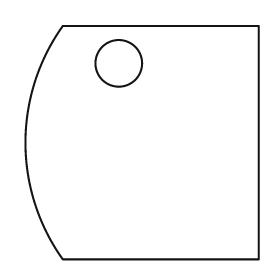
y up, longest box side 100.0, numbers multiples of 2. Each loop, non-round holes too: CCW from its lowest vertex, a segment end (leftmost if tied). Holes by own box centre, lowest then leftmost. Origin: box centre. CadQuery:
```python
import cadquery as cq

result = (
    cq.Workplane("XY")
    .moveTo(-34.0, -50.0)
    .lineTo(50.0, -50.0)
    .lineTo(50.0, 50.0)
    .lineTo(-34.0, 50.0)
    .threePointArc((-50.0, 0.0), (-34.0, -50.0))
    .close()
    .moveTo(-10.0, 34.0)
    .circle(10.0)
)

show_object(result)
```